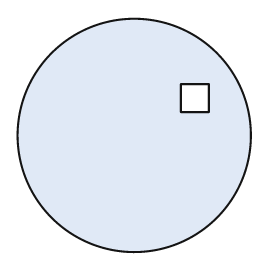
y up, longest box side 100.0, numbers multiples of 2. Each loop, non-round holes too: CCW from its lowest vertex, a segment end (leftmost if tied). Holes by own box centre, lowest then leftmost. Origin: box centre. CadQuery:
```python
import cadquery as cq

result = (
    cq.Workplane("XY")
    .moveTo(0.0, 0.0)
    .circle(50.0)
    .moveTo(20.0, 10.0)
    .lineTo(32.0, 10.0)
    .lineTo(32.0, 22.0)
    .lineTo(20.0, 22.0)
    .close()
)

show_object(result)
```